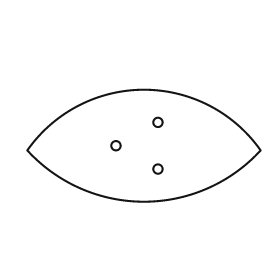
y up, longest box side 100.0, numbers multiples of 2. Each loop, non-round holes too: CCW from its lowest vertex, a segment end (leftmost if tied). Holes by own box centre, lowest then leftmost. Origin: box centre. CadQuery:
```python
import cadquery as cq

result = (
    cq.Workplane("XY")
    .moveTo(-50.0, -2.0)
    .threePointArc((0.0, -24.0), (50.0, -2.0))
    .threePointArc((0.0, 24.0), (-50.0, -2.0))
    .close()
    .moveTo(6.0, -10.0)
    .circle(2.0)
    .moveTo(-12.0, 0.0)
    .circle(2.0)
    .moveTo(6.0, 10.0)
    .circle(2.0)
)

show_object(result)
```